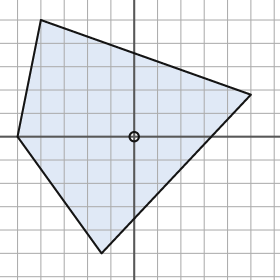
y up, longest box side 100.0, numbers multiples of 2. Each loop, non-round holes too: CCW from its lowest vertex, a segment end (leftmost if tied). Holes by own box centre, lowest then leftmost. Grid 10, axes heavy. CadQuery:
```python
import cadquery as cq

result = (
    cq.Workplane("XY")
    .moveTo(-14.0, -50.0)
    .lineTo(50.0, 18.0)
    .lineTo(-40.0, 50.0)
    .lineTo(-50.0, 0.0)
    .close()
    .moveTo(0.0, 0.0)
    .circle(2.0)
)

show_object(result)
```